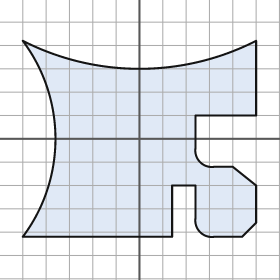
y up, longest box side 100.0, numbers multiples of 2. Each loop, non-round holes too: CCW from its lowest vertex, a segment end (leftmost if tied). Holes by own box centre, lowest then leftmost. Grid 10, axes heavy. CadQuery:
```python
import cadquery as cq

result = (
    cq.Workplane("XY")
    .moveTo(-50.0, -42.0)
    .lineTo(14.0, -42.0)
    .lineTo(14.0, -20.0)
    .lineTo(24.0, -20.0)
    .lineTo(24.0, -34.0)
    .threePointArc((26.0, -40.0), (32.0, -42.0))
    .lineTo(44.0, -42.0)
    .lineTo(50.0, -36.0)
    .lineTo(50.0, -20.0)
    .lineTo(40.0, -12.0)
    .lineTo(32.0, -12.0)
    .threePointArc((26.0, -10.0), (24.0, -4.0))
    .lineTo(24.0, 10.0)
    .lineTo(50.0, 10.0)
    .lineTo(50.0, 42.0)
    .threePointArc((0.0, 30.0), (-50.0, 42.0))
    .threePointArc((-36.0, 0.0), (-50.0, -42.0))
    .close()
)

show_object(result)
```